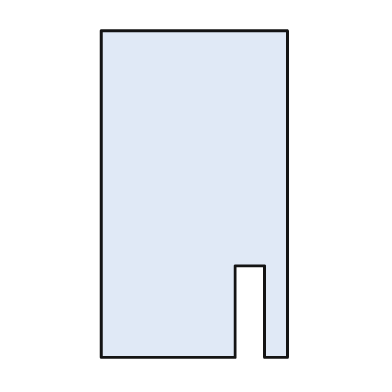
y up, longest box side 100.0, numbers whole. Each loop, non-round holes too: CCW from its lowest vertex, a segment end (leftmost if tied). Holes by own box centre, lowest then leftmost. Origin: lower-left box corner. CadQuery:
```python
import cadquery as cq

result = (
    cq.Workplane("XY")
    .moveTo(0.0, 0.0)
    .lineTo(41.0, 0.0)
    .lineTo(41.0, 28.0)
    .lineTo(50.0, 28.0)
    .lineTo(50.0, 0.0)
    .lineTo(57.0, 0.0)
    .lineTo(57.0, 100.0)
    .lineTo(0.0, 100.0)
    .close()
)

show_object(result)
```